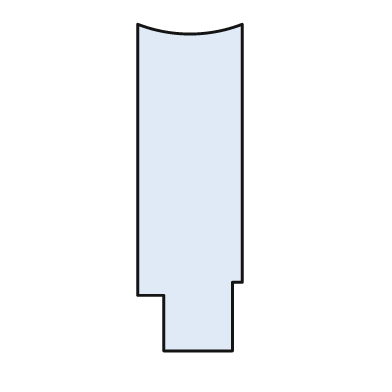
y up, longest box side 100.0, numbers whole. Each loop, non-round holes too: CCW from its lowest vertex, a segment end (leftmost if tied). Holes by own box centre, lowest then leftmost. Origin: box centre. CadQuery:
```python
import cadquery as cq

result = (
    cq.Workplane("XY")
    .moveTo(-8.0, -50.0)
    .lineTo(13.0, -50.0)
    .lineTo(13.0, -29.0)
    .lineTo(16.0, -29.0)
    .lineTo(16.0, 50.0)
    .threePointArc((0.0, 47.0), (-16.0, 50.0))
    .lineTo(-16.0, -33.0)
    .lineTo(-8.0, -33.0)
    .close()
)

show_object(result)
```